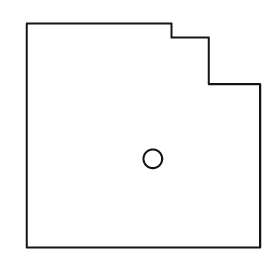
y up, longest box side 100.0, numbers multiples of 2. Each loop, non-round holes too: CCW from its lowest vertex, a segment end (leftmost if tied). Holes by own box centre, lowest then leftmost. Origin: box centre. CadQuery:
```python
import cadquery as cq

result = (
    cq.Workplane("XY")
    .moveTo(-50.0, -48.0)
    .lineTo(50.0, -48.0)
    .lineTo(50.0, 22.0)
    .lineTo(28.0, 22.0)
    .lineTo(28.0, 42.0)
    .lineTo(12.0, 42.0)
    .lineTo(12.0, 48.0)
    .lineTo(-50.0, 48.0)
    .close()
    .moveTo(4.0, -10.0)
    .circle(4.0)
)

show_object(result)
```